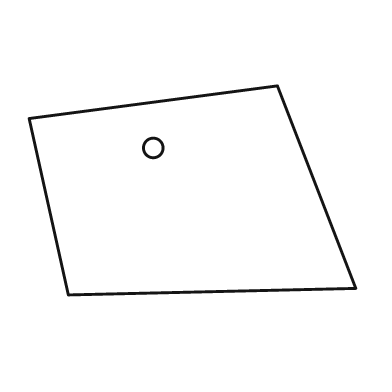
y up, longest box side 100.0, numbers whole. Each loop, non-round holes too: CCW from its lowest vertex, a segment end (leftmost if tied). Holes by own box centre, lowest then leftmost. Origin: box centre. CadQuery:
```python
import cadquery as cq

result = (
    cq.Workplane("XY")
    .moveTo(-38.0, -32.0)
    .lineTo(50.0, -30.0)
    .lineTo(26.0, 32.0)
    .lineTo(-50.0, 22.0)
    .close()
    .moveTo(-12.0, 13.0)
    .circle(3.0)
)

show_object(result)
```